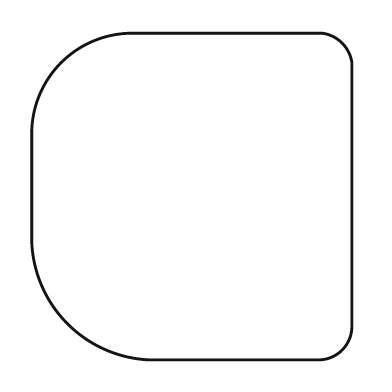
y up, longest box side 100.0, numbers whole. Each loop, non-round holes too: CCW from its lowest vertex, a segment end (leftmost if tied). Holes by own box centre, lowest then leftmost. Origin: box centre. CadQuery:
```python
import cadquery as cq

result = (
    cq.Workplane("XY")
    .moveTo(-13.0, -50.0)
    .lineTo(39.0, -50.0)
    .threePointArc((46.0, -47.0), (49.0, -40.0))
    .lineTo(49.0, 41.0)
    .threePointArc((46.0, 47.0), (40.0, 50.0))
    .lineTo(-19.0, 50.0)
    .threePointArc((-40.0, 41.0), (-49.0, 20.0))
    .lineTo(-49.0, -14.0)
    .threePointArc((-38.0, -39.0), (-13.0, -50.0))
    .close()
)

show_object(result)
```